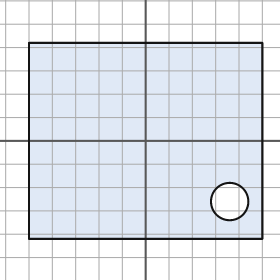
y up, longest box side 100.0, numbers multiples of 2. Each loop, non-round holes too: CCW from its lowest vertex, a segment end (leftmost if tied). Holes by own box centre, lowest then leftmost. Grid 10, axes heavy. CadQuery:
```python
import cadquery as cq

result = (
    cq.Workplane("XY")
    .moveTo(-50.0, -42.0)
    .lineTo(50.0, -42.0)
    .lineTo(50.0, 42.0)
    .lineTo(-50.0, 42.0)
    .close()
    .moveTo(36.0, -26.0)
    .circle(8.0)
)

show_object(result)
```